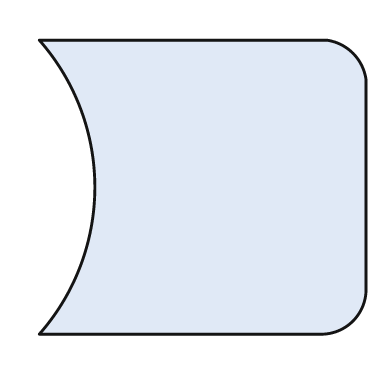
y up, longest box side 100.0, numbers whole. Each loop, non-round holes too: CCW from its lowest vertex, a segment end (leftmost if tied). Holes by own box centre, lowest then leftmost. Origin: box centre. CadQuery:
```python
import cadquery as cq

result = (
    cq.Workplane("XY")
    .moveTo(-50.0, -45.0)
    .lineTo(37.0, -45.0)
    .threePointArc((46.0, -41.0), (50.0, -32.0))
    .lineTo(50.0, 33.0)
    .threePointArc((46.0, 41.0), (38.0, 45.0))
    .lineTo(-50.0, 45.0)
    .threePointArc((-33.0, 0.0), (-50.0, -45.0))
    .close()
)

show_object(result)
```